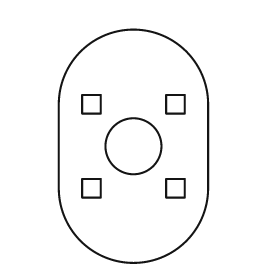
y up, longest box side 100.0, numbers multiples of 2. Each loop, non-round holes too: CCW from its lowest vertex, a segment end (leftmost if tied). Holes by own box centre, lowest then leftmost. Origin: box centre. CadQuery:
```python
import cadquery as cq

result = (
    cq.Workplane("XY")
    .moveTo(-32.0, -18.0)
    .threePointArc((0.0, -50.0), (32.0, -18.0))
    .lineTo(32.0, 18.0)
    .threePointArc((0.0, 50.0), (-32.0, 18.0))
    .close()
    .moveTo(-22.0, -22.0)
    .lineTo(-14.0, -22.0)
    .lineTo(-14.0, -14.0)
    .lineTo(-22.0, -14.0)
    .close()
    .moveTo(14.0, -22.0)
    .lineTo(22.0, -22.0)
    .lineTo(22.0, -14.0)
    .lineTo(14.0, -14.0)
    .close()
    .moveTo(0.0, 0.0)
    .circle(12.0)
    .moveTo(-22.0, 14.0)
    .lineTo(-14.0, 14.0)
    .lineTo(-14.0, 22.0)
    .lineTo(-22.0, 22.0)
    .close()
    .moveTo(14.0, 14.0)
    .lineTo(22.0, 14.0)
    .lineTo(22.0, 22.0)
    .lineTo(14.0, 22.0)
    .close()
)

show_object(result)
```